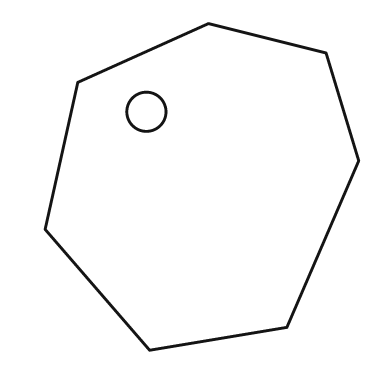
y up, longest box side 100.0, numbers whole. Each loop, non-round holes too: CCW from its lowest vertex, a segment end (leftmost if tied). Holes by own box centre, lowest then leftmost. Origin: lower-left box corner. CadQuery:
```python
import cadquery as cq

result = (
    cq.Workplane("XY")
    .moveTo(32.0, 0.0)
    .lineTo(74.0, 7.0)
    .lineTo(96.0, 58.0)
    .lineTo(86.0, 91.0)
    .lineTo(50.0, 100.0)
    .lineTo(10.0, 82.0)
    .lineTo(0.0, 37.0)
    .close()
    .moveTo(31.0, 73.0)
    .circle(6.0)
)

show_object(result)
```